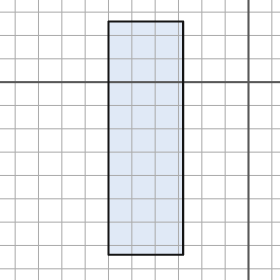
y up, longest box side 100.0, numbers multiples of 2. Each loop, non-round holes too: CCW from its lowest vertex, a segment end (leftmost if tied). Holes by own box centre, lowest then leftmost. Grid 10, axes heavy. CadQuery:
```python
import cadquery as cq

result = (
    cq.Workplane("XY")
    .moveTo(-60.0, -74.0)
    .lineTo(-28.0, -74.0)
    .lineTo(-28.0, 26.0)
    .lineTo(-60.0, 26.0)
    .close()
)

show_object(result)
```